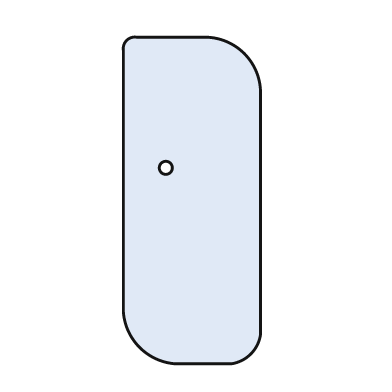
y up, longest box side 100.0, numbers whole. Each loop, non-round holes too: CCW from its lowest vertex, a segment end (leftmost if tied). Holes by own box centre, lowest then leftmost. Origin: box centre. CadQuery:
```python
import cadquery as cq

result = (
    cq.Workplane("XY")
    .moveTo(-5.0, -50.0)
    .lineTo(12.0, -50.0)
    .threePointArc((18.0, -47.0), (21.0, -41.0))
    .lineTo(21.0, 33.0)
    .threePointArc((16.0, 45.0), (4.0, 50.0))
    .lineTo(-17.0, 50.0)
    .threePointArc((-20.0, 49.0), (-21.0, 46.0))
    .lineTo(-21.0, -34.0)
    .threePointArc((-16.0, -45.0), (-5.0, -50.0))
    .close()
    .moveTo(-8.0, 10.0)
    .circle(2.0)
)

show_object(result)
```